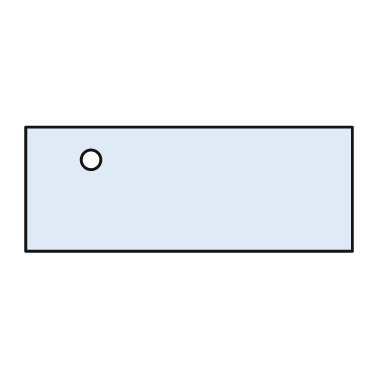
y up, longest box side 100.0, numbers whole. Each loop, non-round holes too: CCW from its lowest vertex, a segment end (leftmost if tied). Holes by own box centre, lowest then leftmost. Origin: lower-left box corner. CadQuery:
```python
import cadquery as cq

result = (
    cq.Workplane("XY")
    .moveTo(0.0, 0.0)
    .lineTo(100.0, 0.0)
    .lineTo(100.0, 38.0)
    .lineTo(0.0, 38.0)
    .close()
    .moveTo(20.0, 28.0)
    .circle(3.0)
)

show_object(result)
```